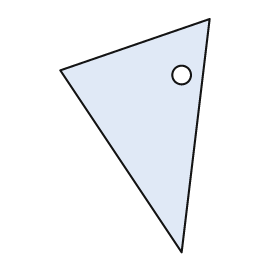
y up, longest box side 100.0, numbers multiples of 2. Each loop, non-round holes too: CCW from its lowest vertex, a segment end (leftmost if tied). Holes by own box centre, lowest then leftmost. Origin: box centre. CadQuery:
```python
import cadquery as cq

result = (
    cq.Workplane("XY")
    .moveTo(20.0, -50.0)
    .lineTo(32.0, 50.0)
    .lineTo(-32.0, 28.0)
    .close()
    .moveTo(20.0, 26.0)
    .circle(4.0)
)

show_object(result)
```